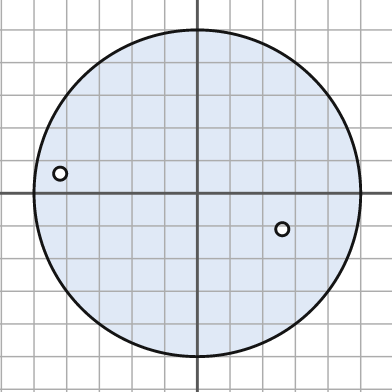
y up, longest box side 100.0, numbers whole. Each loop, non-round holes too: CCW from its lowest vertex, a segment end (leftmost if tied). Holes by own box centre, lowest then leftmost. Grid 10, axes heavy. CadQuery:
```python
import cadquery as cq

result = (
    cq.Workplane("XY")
    .moveTo(0.0, 0.0)
    .circle(50.0)
    .moveTo(26.0, -11.0)
    .circle(2.0)
    .moveTo(-42.0, 6.0)
    .circle(2.0)
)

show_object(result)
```